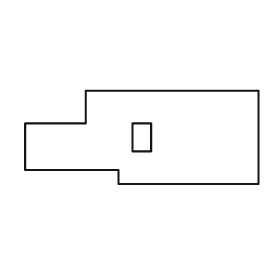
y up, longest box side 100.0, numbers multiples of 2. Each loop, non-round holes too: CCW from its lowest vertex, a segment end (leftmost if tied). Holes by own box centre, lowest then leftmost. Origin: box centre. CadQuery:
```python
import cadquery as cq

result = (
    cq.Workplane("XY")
    .moveTo(-10.0, -20.0)
    .lineTo(50.0, -20.0)
    .lineTo(50.0, 20.0)
    .lineTo(-24.0, 20.0)
    .lineTo(-24.0, 6.0)
    .lineTo(-50.0, 6.0)
    .lineTo(-50.0, -14.0)
    .lineTo(-10.0, -14.0)
    .close()
    .moveTo(-4.0, -6.0)
    .lineTo(4.0, -6.0)
    .lineTo(4.0, 6.0)
    .lineTo(-4.0, 6.0)
    .close()
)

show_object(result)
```